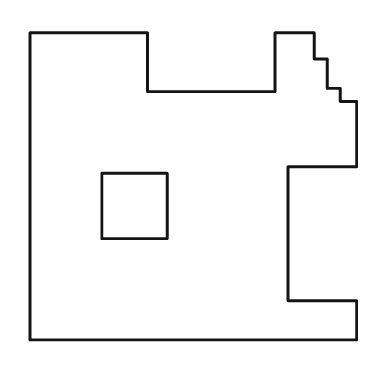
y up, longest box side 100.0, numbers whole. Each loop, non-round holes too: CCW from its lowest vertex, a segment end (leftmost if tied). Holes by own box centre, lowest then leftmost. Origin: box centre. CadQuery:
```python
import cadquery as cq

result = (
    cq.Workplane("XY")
    .moveTo(-50.0, -47.0)
    .lineTo(50.0, -47.0)
    .lineTo(50.0, -35.0)
    .lineTo(29.0, -35.0)
    .lineTo(29.0, 6.0)
    .lineTo(50.0, 6.0)
    .lineTo(50.0, 26.0)
    .lineTo(45.0, 26.0)
    .lineTo(45.0, 30.0)
    .lineTo(41.0, 30.0)
    .lineTo(41.0, 39.0)
    .lineTo(37.0, 39.0)
    .lineTo(37.0, 47.0)
    .lineTo(25.0, 47.0)
    .lineTo(25.0, 29.0)
    .lineTo(-14.0, 29.0)
    .lineTo(-14.0, 47.0)
    .lineTo(-50.0, 47.0)
    .close()
    .moveTo(-28.0, -16.0)
    .lineTo(-8.0, -16.0)
    .lineTo(-8.0, 4.0)
    .lineTo(-28.0, 4.0)
    .close()
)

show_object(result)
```